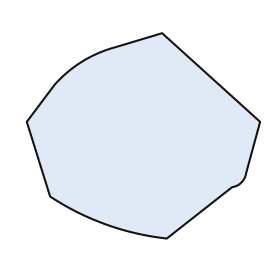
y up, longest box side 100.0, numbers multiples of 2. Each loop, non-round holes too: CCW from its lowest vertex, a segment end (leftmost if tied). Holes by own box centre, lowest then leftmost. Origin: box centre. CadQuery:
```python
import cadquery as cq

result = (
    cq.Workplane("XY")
    .moveTo(10.0, -44.0)
    .lineTo(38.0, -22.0)
    .threePointArc((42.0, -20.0), (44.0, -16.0))
    .lineTo(50.0, 6.0)
    .lineTo(8.0, 44.0)
    .lineTo(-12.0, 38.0)
    .threePointArc((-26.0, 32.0), (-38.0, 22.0))
    .lineTo(-50.0, 6.0)
    .lineTo(-40.0, -26.0)
    .threePointArc((-16.0, -38.0), (10.0, -44.0))
    .close()
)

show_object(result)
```